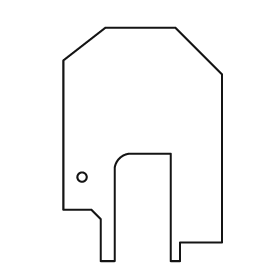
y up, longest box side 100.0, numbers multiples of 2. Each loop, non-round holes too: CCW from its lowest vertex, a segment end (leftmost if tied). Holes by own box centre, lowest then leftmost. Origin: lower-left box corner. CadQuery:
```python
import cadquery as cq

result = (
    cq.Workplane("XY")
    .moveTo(16.0, 0.0)
    .lineTo(22.0, 0.0)
    .lineTo(22.0, 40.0)
    .threePointArc((24.0, 44.0), (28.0, 46.0))
    .lineTo(46.0, 46.0)
    .lineTo(46.0, 0.0)
    .lineTo(50.0, 0.0)
    .lineTo(50.0, 8.0)
    .lineTo(68.0, 8.0)
    .lineTo(68.0, 80.0)
    .lineTo(48.0, 100.0)
    .lineTo(18.0, 100.0)
    .lineTo(0.0, 86.0)
    .lineTo(0.0, 22.0)
    .lineTo(12.0, 22.0)
    .lineTo(16.0, 18.0)
    .close()
    .moveTo(8.0, 36.0)
    .circle(2.0)
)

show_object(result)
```